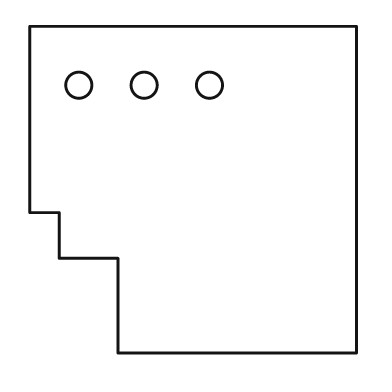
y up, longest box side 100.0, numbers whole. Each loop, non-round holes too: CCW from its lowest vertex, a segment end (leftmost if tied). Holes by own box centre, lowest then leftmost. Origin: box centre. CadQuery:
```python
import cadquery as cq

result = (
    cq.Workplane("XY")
    .moveTo(-23.0, -50.0)
    .lineTo(50.0, -50.0)
    .lineTo(50.0, 50.0)
    .lineTo(-50.0, 50.0)
    .lineTo(-50.0, -7.0)
    .lineTo(-41.0, -7.0)
    .lineTo(-41.0, -21.0)
    .lineTo(-23.0, -21.0)
    .close()
    .moveTo(-35.0, 32.0)
    .circle(4.0)
    .moveTo(-15.0, 32.0)
    .circle(4.0)
    .moveTo(5.0, 32.0)
    .circle(4.0)
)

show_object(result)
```